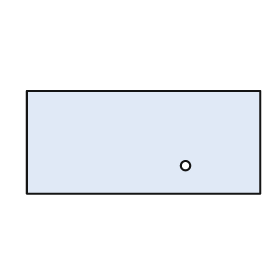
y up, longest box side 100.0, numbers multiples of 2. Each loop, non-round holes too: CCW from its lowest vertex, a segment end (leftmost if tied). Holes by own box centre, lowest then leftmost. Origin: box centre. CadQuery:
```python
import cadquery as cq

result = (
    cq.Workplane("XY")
    .moveTo(-50.0, -22.0)
    .lineTo(50.0, -22.0)
    .lineTo(50.0, 22.0)
    .lineTo(-50.0, 22.0)
    .close()
    .moveTo(18.0, -10.0)
    .circle(2.0)
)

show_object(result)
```